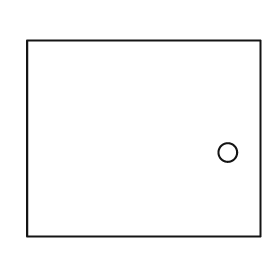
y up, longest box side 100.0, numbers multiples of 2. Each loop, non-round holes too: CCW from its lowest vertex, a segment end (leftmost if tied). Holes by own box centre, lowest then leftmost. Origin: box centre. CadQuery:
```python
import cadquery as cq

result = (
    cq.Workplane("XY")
    .moveTo(-50.0, -42.0)
    .lineTo(50.0, -42.0)
    .lineTo(50.0, 42.0)
    .lineTo(-50.0, 42.0)
    .close()
    .moveTo(36.0, -6.0)
    .circle(4.0)
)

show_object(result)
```